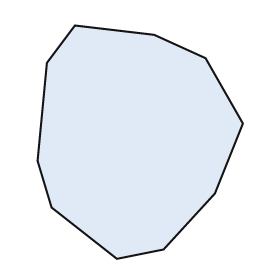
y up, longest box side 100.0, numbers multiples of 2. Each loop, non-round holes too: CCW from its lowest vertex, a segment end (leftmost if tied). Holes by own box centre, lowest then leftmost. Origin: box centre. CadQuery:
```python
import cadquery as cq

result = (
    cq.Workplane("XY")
    .moveTo(-10.0, -50.0)
    .lineTo(10.0, -46.0)
    .lineTo(32.0, -22.0)
    .lineTo(44.0, 8.0)
    .lineTo(28.0, 36.0)
    .lineTo(6.0, 46.0)
    .lineTo(-28.0, 50.0)
    .lineTo(-40.0, 34.0)
    .lineTo(-44.0, -8.0)
    .lineTo(-38.0, -28.0)
    .close()
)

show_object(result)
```